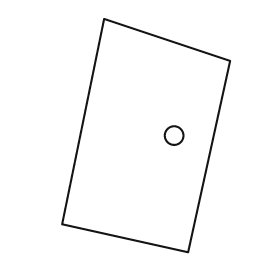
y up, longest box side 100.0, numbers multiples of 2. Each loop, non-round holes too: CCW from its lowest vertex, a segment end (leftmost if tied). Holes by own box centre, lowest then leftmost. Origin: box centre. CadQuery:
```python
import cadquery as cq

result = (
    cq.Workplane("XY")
    .moveTo(18.0, -50.0)
    .lineTo(36.0, 32.0)
    .lineTo(-18.0, 50.0)
    .lineTo(-36.0, -38.0)
    .close()
    .moveTo(12.0, 0.0)
    .circle(4.0)
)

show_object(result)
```